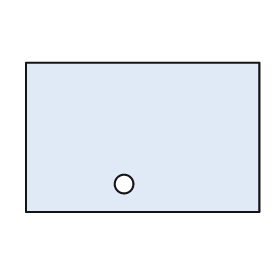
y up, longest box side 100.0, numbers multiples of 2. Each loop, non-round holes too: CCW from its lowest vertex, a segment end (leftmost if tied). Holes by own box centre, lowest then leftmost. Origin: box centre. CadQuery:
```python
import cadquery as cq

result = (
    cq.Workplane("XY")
    .moveTo(-50.0, -32.0)
    .lineTo(50.0, -32.0)
    .lineTo(50.0, 32.0)
    .lineTo(-50.0, 32.0)
    .close()
    .moveTo(-8.0, -20.0)
    .circle(4.0)
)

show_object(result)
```